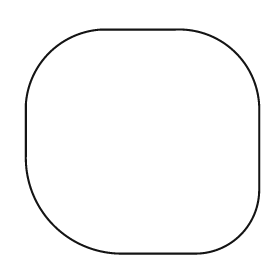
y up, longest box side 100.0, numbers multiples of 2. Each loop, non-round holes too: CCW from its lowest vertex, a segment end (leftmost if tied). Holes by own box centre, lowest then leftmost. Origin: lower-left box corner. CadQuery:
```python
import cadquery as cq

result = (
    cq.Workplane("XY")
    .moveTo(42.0, 0.0)
    .lineTo(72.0, 0.0)
    .threePointArc((92.0, 8.0), (100.0, 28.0))
    .lineTo(100.0, 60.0)
    .threePointArc((90.0, 86.0), (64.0, 96.0))
    .lineTo(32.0, 96.0)
    .threePointArc((10.0, 86.0), (0.0, 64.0))
    .lineTo(0.0, 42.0)
    .threePointArc((12.0, 12.0), (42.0, 0.0))
    .close()
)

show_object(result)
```